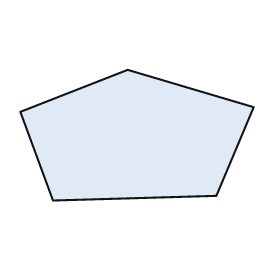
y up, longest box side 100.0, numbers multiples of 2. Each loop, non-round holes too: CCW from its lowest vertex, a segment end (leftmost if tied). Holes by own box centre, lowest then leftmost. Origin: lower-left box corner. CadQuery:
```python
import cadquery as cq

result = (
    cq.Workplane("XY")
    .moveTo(14.0, 0.0)
    .lineTo(84.0, 2.0)
    .lineTo(100.0, 40.0)
    .lineTo(46.0, 56.0)
    .lineTo(0.0, 38.0)
    .close()
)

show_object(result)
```